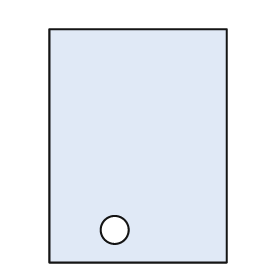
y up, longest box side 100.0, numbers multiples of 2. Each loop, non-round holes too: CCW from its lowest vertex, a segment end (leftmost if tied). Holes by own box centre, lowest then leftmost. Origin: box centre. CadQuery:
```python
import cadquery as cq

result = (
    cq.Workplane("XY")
    .moveTo(-38.0, -50.0)
    .lineTo(38.0, -50.0)
    .lineTo(38.0, 50.0)
    .lineTo(-38.0, 50.0)
    .close()
    .moveTo(-10.0, -36.0)
    .circle(6.0)
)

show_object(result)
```